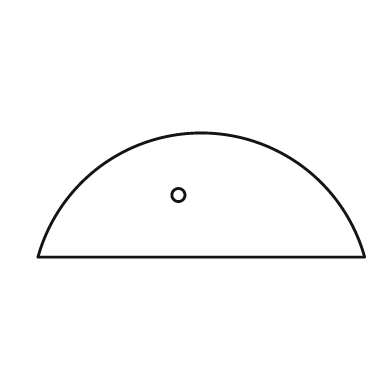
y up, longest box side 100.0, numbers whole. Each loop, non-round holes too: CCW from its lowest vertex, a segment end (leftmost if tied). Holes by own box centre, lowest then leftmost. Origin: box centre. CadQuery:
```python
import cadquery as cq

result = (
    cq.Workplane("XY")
    .moveTo(-50.0, -19.0)
    .lineTo(50.0, -19.0)
    .threePointArc((0.0, 19.0), (-50.0, -19.0))
    .close()
    .moveTo(-7.0, 0.0)
    .circle(2.0)
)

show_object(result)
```